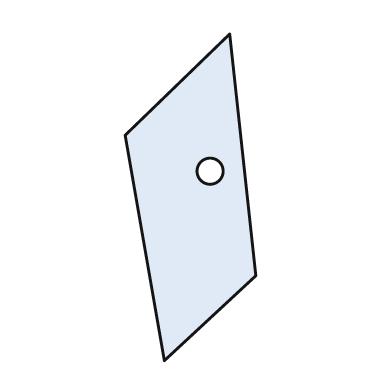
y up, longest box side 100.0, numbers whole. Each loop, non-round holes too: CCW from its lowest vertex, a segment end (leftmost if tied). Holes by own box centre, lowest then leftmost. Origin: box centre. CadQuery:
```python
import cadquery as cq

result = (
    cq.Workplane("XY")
    .moveTo(-8.0, -50.0)
    .lineTo(20.0, -24.0)
    .lineTo(12.0, 50.0)
    .lineTo(-20.0, 19.0)
    .close()
    .moveTo(6.0, 8.0)
    .circle(4.0)
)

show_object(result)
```